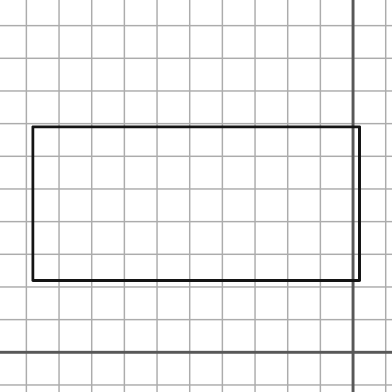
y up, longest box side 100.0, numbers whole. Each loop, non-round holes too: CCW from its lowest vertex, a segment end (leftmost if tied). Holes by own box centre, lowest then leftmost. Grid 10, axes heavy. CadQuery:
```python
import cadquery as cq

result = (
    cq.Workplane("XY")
    .moveTo(-98.0, 22.0)
    .lineTo(2.0, 22.0)
    .lineTo(2.0, 69.0)
    .lineTo(-98.0, 69.0)
    .close()
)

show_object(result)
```